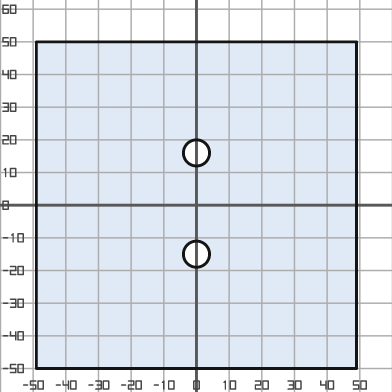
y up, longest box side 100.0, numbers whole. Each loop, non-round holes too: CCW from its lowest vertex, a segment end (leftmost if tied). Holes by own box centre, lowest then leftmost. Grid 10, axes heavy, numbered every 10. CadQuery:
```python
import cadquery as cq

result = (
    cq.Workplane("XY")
    .moveTo(-49.0, -50.0)
    .lineTo(49.0, -50.0)
    .lineTo(49.0, 50.0)
    .lineTo(-49.0, 50.0)
    .close()
    .moveTo(0.0, -15.0)
    .circle(4.0)
    .moveTo(0.0, 16.0)
    .circle(4.0)
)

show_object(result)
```